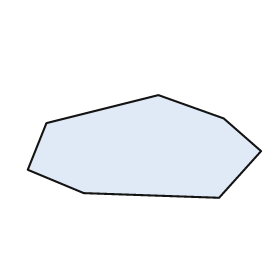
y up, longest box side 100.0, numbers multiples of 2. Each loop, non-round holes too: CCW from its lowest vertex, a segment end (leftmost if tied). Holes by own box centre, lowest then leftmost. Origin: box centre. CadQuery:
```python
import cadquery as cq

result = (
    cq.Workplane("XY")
    .moveTo(32.0, -22.0)
    .lineTo(50.0, -2.0)
    .lineTo(34.0, 12.0)
    .lineTo(6.0, 22.0)
    .lineTo(-42.0, 10.0)
    .lineTo(-50.0, -10.0)
    .lineTo(-26.0, -20.0)
    .close()
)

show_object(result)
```